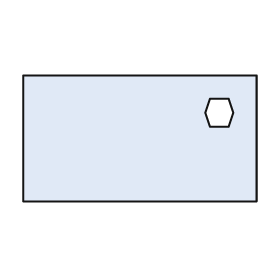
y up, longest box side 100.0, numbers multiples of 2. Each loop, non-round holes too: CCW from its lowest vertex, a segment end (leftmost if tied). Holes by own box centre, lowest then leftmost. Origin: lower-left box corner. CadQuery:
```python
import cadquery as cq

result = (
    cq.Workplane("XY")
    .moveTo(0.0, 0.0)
    .lineTo(100.0, 0.0)
    .lineTo(100.0, 54.0)
    .lineTo(0.0, 54.0)
    .close()
    .moveTo(80.0, 32.0)
    .lineTo(88.0, 32.0)
    .lineTo(90.0, 38.0)
    .lineTo(88.0, 44.0)
    .lineTo(80.0, 44.0)
    .lineTo(78.0, 38.0)
    .close()
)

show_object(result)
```